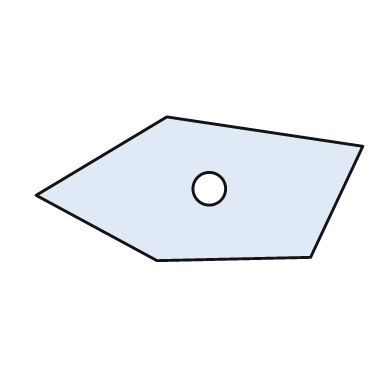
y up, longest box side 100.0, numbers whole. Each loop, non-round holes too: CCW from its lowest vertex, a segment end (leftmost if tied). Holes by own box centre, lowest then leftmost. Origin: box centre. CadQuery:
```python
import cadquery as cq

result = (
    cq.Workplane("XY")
    .moveTo(-13.0, -22.0)
    .lineTo(34.0, -21.0)
    .lineTo(50.0, 13.0)
    .lineTo(-10.0, 22.0)
    .lineTo(-50.0, -2.0)
    .close()
    .moveTo(3.0, 0.0)
    .circle(5.0)
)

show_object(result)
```